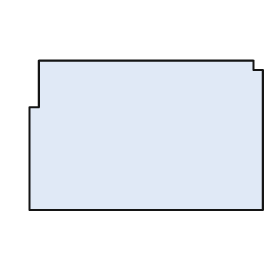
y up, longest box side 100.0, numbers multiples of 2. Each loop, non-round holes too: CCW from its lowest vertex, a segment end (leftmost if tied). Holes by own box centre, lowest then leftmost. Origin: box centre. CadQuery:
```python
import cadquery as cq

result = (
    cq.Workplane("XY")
    .moveTo(-50.0, -32.0)
    .lineTo(50.0, -32.0)
    .lineTo(50.0, 28.0)
    .lineTo(46.0, 28.0)
    .lineTo(46.0, 32.0)
    .lineTo(-46.0, 32.0)
    .lineTo(-46.0, 12.0)
    .lineTo(-50.0, 12.0)
    .close()
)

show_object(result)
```